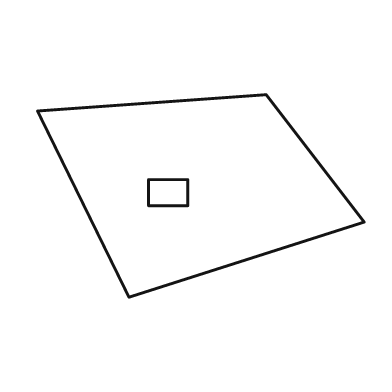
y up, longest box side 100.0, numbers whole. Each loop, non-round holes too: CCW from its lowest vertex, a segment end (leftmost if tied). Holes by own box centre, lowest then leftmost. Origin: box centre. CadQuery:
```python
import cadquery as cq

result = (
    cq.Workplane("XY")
    .moveTo(-22.0, -31.0)
    .lineTo(50.0, -8.0)
    .lineTo(20.0, 31.0)
    .lineTo(-50.0, 26.0)
    .close()
    .moveTo(-16.0, -3.0)
    .lineTo(-4.0, -3.0)
    .lineTo(-4.0, 5.0)
    .lineTo(-16.0, 5.0)
    .close()
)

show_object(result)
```